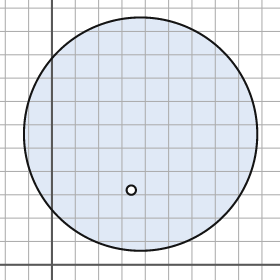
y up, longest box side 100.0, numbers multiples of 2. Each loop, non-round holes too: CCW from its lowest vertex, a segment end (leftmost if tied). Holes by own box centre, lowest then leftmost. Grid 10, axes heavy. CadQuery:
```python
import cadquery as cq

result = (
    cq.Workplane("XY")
    .moveTo(38.0, 56.0)
    .circle(50.0)
    .moveTo(34.0, 32.0)
    .circle(2.0)
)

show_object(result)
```